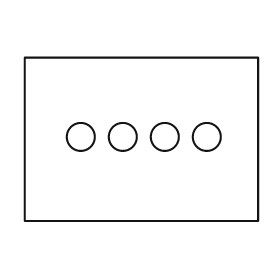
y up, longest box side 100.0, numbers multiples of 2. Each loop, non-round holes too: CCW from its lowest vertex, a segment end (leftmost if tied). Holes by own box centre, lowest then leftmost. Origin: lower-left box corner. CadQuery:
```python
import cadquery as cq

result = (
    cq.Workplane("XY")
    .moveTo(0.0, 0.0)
    .lineTo(100.0, 0.0)
    .lineTo(100.0, 70.0)
    .lineTo(0.0, 70.0)
    .close()
    .moveTo(24.0, 36.0)
    .circle(6.0)
    .moveTo(42.0, 36.0)
    .circle(6.0)
    .moveTo(60.0, 36.0)
    .circle(6.0)
    .moveTo(78.0, 36.0)
    .circle(6.0)
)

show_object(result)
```